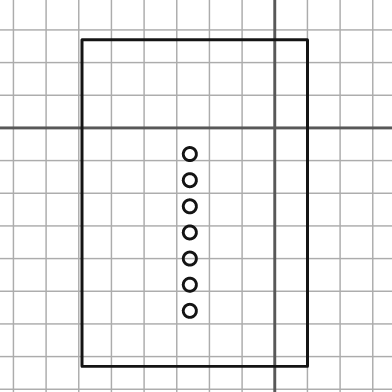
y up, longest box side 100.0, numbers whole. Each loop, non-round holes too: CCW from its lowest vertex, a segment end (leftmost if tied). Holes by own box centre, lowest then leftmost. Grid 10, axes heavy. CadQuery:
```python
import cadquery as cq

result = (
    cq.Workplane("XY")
    .moveTo(-59.0, -73.0)
    .lineTo(10.0, -73.0)
    .lineTo(10.0, 27.0)
    .lineTo(-59.0, 27.0)
    .close()
    .moveTo(-26.0, -56.0)
    .circle(2.0)
    .moveTo(-26.0, -48.0)
    .circle(2.0)
    .moveTo(-26.0, -40.0)
    .circle(2.0)
    .moveTo(-26.0, -32.0)
    .circle(2.0)
    .moveTo(-26.0, -24.0)
    .circle(2.0)
    .moveTo(-26.0, -16.0)
    .circle(2.0)
    .moveTo(-26.0, -8.0)
    .circle(2.0)
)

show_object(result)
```